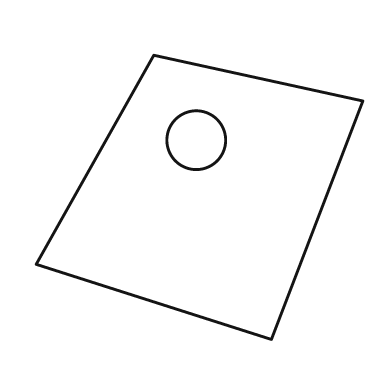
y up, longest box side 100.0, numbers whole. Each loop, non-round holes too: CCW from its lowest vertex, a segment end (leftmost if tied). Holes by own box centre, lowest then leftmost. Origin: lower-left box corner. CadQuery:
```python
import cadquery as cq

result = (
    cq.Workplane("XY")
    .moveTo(72.0, 0.0)
    .lineTo(100.0, 73.0)
    .lineTo(36.0, 87.0)
    .lineTo(0.0, 23.0)
    .close()
    .moveTo(49.0, 61.0)
    .circle(9.0)
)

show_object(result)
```